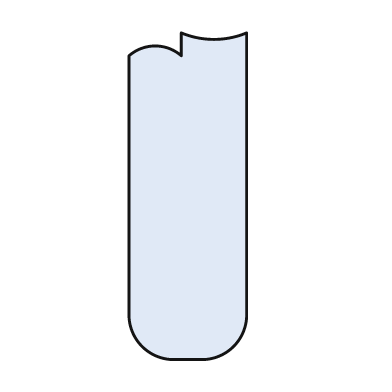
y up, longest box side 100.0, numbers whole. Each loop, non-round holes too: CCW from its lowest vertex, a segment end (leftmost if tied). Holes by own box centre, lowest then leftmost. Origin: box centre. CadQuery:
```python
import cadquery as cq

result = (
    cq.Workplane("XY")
    .moveTo(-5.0, -50.0)
    .lineTo(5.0, -50.0)
    .threePointArc((14.0, -46.0), (18.0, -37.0))
    .lineTo(18.0, 50.0)
    .threePointArc((8.0, 48.0), (-2.0, 50.0))
    .lineTo(-2.0, 43.0)
    .threePointArc((-10.0, 46.0), (-18.0, 43.0))
    .lineTo(-18.0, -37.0)
    .threePointArc((-14.0, -46.0), (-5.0, -50.0))
    .close()
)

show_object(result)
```